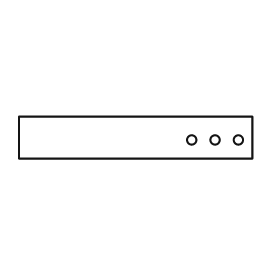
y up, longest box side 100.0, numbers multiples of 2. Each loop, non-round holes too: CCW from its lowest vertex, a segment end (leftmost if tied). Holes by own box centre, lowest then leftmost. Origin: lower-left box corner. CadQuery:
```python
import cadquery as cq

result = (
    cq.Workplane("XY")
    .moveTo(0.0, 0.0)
    .lineTo(100.0, 0.0)
    .lineTo(100.0, 18.0)
    .lineTo(0.0, 18.0)
    .close()
    .moveTo(74.0, 8.0)
    .circle(2.0)
    .moveTo(84.0, 8.0)
    .circle(2.0)
    .moveTo(94.0, 8.0)
    .circle(2.0)
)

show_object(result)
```